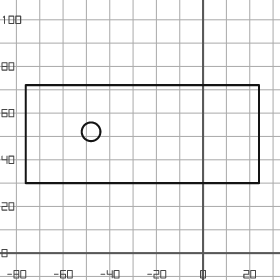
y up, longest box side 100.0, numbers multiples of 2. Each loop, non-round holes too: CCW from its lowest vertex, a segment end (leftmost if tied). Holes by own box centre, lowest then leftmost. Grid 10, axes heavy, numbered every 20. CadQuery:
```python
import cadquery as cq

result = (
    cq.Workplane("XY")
    .moveTo(-76.0, 30.0)
    .lineTo(24.0, 30.0)
    .lineTo(24.0, 72.0)
    .lineTo(-76.0, 72.0)
    .close()
    .moveTo(-48.0, 52.0)
    .circle(4.0)
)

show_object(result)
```